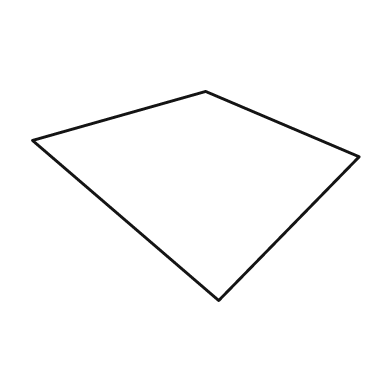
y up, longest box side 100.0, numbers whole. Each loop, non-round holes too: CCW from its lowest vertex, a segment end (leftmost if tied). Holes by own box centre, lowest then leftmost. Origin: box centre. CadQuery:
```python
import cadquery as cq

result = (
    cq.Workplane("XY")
    .moveTo(7.0, -32.0)
    .lineTo(50.0, 12.0)
    .lineTo(3.0, 32.0)
    .lineTo(-50.0, 17.0)
    .close()
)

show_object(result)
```